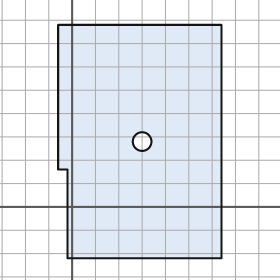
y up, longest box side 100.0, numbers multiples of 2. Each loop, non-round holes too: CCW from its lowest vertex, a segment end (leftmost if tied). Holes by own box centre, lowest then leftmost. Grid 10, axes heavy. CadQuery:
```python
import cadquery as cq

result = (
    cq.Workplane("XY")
    .moveTo(-2.0, -22.0)
    .lineTo(64.0, -22.0)
    .lineTo(64.0, 78.0)
    .lineTo(-6.0, 78.0)
    .lineTo(-6.0, 16.0)
    .lineTo(-2.0, 16.0)
    .close()
    .moveTo(30.0, 28.0)
    .circle(4.0)
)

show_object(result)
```